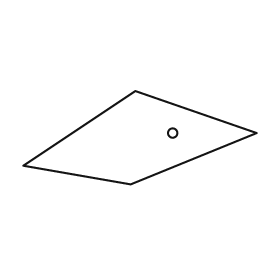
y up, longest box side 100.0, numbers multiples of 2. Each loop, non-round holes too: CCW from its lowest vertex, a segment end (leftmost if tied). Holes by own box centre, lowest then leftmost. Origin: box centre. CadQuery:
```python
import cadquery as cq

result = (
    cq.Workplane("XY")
    .moveTo(-4.0, -20.0)
    .lineTo(50.0, 2.0)
    .lineTo(-2.0, 20.0)
    .lineTo(-50.0, -12.0)
    .close()
    .moveTo(14.0, 2.0)
    .circle(2.0)
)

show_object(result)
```